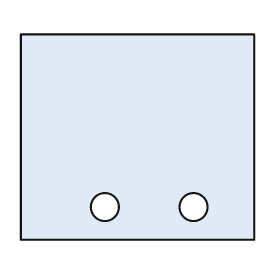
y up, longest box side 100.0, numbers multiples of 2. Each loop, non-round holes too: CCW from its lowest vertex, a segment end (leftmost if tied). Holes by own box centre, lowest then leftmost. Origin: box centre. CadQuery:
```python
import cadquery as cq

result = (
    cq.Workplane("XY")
    .moveTo(-50.0, -44.0)
    .lineTo(50.0, -44.0)
    .lineTo(50.0, 44.0)
    .lineTo(-50.0, 44.0)
    .close()
    .moveTo(-14.0, -30.0)
    .circle(6.0)
    .moveTo(24.0, -30.0)
    .circle(6.0)
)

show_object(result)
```